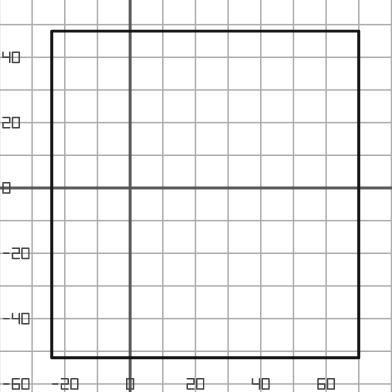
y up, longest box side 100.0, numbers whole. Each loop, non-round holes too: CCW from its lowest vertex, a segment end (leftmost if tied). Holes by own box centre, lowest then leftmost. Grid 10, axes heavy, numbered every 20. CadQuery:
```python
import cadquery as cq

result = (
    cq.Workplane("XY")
    .moveTo(-24.0, -52.0)
    .lineTo(70.0, -52.0)
    .lineTo(70.0, 48.0)
    .lineTo(-24.0, 48.0)
    .close()
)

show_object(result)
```